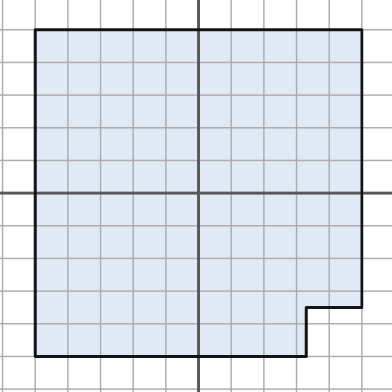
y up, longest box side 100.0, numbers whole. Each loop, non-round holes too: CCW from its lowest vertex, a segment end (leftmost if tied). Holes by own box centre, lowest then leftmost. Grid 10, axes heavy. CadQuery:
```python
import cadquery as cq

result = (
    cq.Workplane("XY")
    .moveTo(-50.0, -50.0)
    .lineTo(33.0, -50.0)
    .lineTo(33.0, -35.0)
    .lineTo(50.0, -35.0)
    .lineTo(50.0, 50.0)
    .lineTo(-50.0, 50.0)
    .close()
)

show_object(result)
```